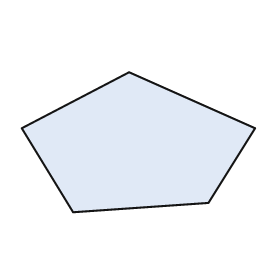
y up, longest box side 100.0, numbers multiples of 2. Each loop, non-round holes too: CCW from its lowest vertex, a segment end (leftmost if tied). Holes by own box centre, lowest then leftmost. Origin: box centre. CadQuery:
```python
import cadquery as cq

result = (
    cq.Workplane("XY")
    .moveTo(-28.0, -30.0)
    .lineTo(30.0, -26.0)
    .lineTo(50.0, 6.0)
    .lineTo(-4.0, 30.0)
    .lineTo(-50.0, 6.0)
    .close()
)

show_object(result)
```